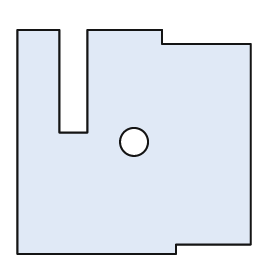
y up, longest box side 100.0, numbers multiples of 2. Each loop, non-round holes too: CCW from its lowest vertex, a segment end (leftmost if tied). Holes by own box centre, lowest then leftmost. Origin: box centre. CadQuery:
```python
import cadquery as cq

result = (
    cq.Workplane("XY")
    .moveTo(-50.0, -48.0)
    .lineTo(18.0, -48.0)
    .lineTo(18.0, -44.0)
    .lineTo(50.0, -44.0)
    .lineTo(50.0, 42.0)
    .lineTo(12.0, 42.0)
    .lineTo(12.0, 48.0)
    .lineTo(-20.0, 48.0)
    .lineTo(-20.0, 4.0)
    .lineTo(-32.0, 4.0)
    .lineTo(-32.0, 48.0)
    .lineTo(-50.0, 48.0)
    .close()
    .moveTo(0.0, 0.0)
    .circle(6.0)
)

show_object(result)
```